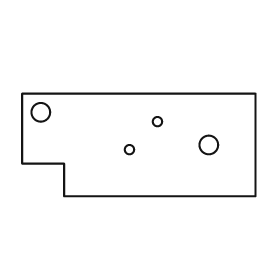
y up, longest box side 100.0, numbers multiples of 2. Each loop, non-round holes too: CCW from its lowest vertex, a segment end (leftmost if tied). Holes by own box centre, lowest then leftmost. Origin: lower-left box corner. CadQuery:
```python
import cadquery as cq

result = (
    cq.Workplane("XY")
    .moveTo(18.0, 0.0)
    .lineTo(100.0, 0.0)
    .lineTo(100.0, 44.0)
    .lineTo(0.0, 44.0)
    .lineTo(0.0, 14.0)
    .lineTo(18.0, 14.0)
    .close()
    .moveTo(46.0, 20.0)
    .circle(2.0)
    .moveTo(80.0, 22.0)
    .circle(4.0)
    .moveTo(58.0, 32.0)
    .circle(2.0)
    .moveTo(8.0, 36.0)
    .circle(4.0)
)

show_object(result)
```